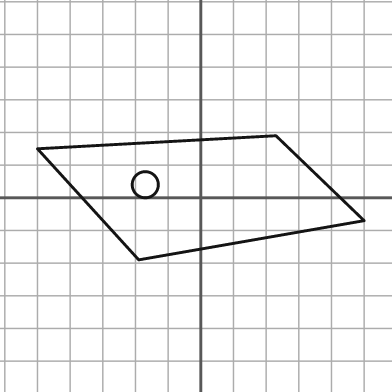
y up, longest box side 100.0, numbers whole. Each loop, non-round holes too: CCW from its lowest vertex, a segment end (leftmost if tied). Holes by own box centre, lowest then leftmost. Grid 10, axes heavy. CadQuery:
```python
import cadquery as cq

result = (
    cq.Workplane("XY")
    .moveTo(-19.0, -19.0)
    .lineTo(50.0, -7.0)
    .lineTo(23.0, 19.0)
    .lineTo(-50.0, 15.0)
    .close()
    .moveTo(-17.0, 4.0)
    .circle(4.0)
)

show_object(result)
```